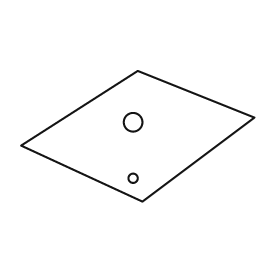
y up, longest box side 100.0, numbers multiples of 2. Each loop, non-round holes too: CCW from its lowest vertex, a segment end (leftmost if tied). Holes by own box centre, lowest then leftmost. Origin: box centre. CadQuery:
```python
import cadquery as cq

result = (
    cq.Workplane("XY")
    .moveTo(2.0, -28.0)
    .lineTo(50.0, 8.0)
    .lineTo(0.0, 28.0)
    .lineTo(-50.0, -4.0)
    .close()
    .moveTo(-2.0, -18.0)
    .circle(2.0)
    .moveTo(-2.0, 6.0)
    .circle(4.0)
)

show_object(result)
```